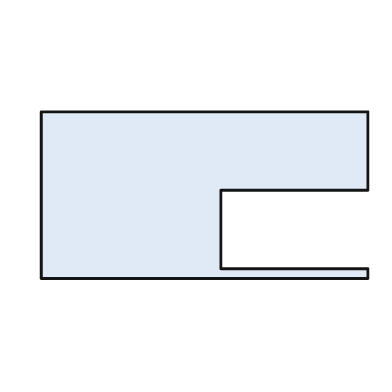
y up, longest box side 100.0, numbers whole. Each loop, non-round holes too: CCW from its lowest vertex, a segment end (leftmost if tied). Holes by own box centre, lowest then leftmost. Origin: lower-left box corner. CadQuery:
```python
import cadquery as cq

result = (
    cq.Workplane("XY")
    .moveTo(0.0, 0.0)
    .lineTo(100.0, 0.0)
    .lineTo(100.0, 3.0)
    .lineTo(55.0, 3.0)
    .lineTo(55.0, 27.0)
    .lineTo(100.0, 27.0)
    .lineTo(100.0, 51.0)
    .lineTo(0.0, 51.0)
    .close()
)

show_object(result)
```